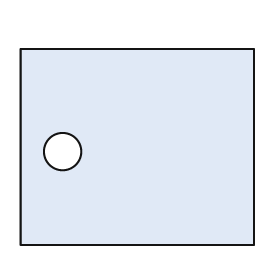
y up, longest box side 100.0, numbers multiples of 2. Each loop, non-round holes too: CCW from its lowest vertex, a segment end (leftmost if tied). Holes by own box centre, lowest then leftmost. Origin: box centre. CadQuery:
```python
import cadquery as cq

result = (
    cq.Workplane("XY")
    .moveTo(-50.0, -42.0)
    .lineTo(50.0, -42.0)
    .lineTo(50.0, 42.0)
    .lineTo(-50.0, 42.0)
    .close()
    .moveTo(-32.0, -2.0)
    .circle(8.0)
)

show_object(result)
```